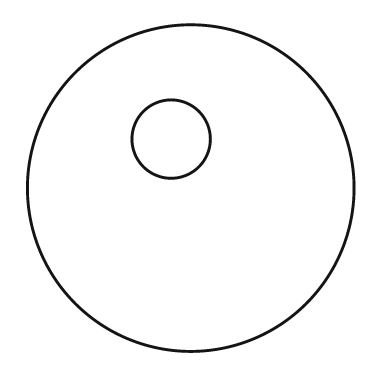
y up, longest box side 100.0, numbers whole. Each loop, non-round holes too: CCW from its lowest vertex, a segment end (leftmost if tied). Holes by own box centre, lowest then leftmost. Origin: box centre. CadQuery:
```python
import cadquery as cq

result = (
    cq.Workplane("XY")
    .moveTo(0.0, 0.0)
    .circle(50.0)
    .moveTo(-6.0, 15.0)
    .circle(12.0)
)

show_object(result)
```